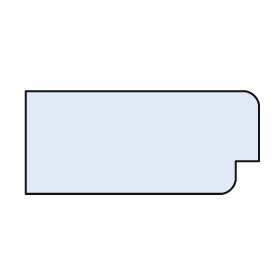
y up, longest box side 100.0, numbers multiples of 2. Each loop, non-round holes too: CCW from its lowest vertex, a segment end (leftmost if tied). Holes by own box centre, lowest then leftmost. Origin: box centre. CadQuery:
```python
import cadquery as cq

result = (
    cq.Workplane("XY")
    .moveTo(-50.0, -22.0)
    .lineTo(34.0, -22.0)
    .threePointArc((38.0, -20.0), (40.0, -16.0))
    .lineTo(40.0, -8.0)
    .lineTo(50.0, -8.0)
    .lineTo(50.0, 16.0)
    .threePointArc((48.0, 20.0), (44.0, 22.0))
    .lineTo(-50.0, 22.0)
    .close()
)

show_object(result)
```